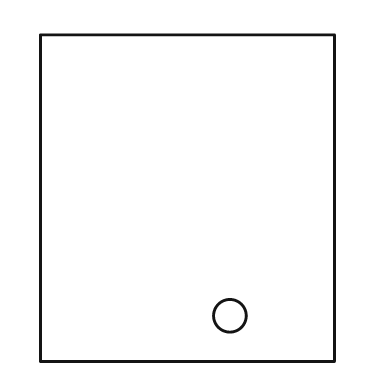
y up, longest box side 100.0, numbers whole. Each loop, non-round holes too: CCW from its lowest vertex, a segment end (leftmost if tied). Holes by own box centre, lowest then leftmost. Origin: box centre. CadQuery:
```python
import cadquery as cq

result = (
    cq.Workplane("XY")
    .moveTo(-45.0, -50.0)
    .lineTo(45.0, -50.0)
    .lineTo(45.0, 50.0)
    .lineTo(-45.0, 50.0)
    .close()
    .moveTo(13.0, -36.0)
    .circle(5.0)
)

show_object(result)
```